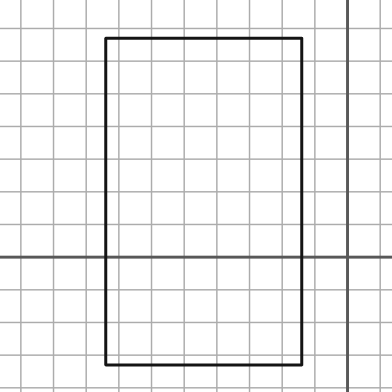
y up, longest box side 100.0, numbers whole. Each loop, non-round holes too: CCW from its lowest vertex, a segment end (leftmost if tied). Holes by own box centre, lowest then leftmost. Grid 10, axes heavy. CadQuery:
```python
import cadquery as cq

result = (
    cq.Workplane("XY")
    .moveTo(-74.0, -33.0)
    .lineTo(-14.0, -33.0)
    .lineTo(-14.0, 67.0)
    .lineTo(-74.0, 67.0)
    .close()
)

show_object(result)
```